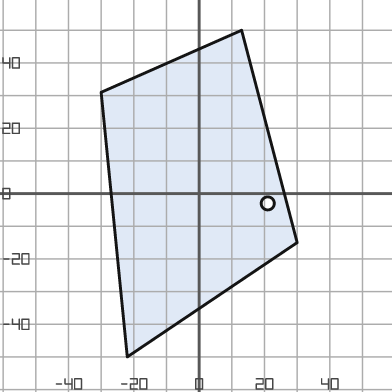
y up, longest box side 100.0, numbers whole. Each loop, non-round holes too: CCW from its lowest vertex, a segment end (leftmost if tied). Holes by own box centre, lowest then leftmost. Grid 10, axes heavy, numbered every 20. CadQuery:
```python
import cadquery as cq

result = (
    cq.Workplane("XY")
    .moveTo(-22.0, -50.0)
    .lineTo(30.0, -15.0)
    .lineTo(13.0, 50.0)
    .lineTo(-30.0, 31.0)
    .close()
    .moveTo(21.0, -3.0)
    .circle(2.0)
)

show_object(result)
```